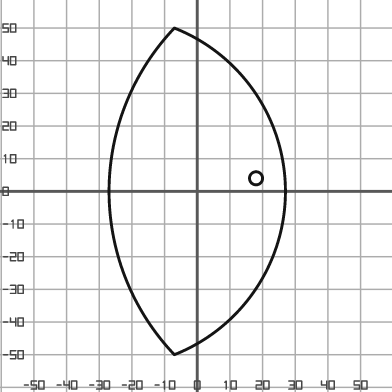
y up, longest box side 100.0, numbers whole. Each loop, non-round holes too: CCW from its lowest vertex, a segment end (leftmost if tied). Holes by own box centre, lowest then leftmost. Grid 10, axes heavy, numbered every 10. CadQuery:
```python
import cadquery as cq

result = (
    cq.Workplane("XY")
    .moveTo(-7.0, -50.0)
    .threePointArc((27.0, 0.0), (-7.0, 50.0))
    .threePointArc((-27.0, 0.0), (-7.0, -50.0))
    .close()
    .moveTo(18.0, 4.0)
    .circle(2.0)
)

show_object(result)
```